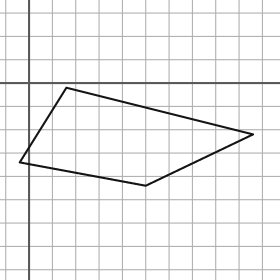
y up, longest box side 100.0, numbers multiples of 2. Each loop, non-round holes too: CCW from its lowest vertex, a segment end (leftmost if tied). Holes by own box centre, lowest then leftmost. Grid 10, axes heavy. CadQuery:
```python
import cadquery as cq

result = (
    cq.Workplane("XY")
    .moveTo(50.0, -44.0)
    .lineTo(96.0, -22.0)
    .lineTo(16.0, -2.0)
    .lineTo(-4.0, -34.0)
    .close()
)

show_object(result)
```